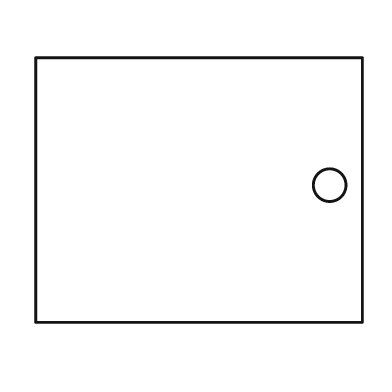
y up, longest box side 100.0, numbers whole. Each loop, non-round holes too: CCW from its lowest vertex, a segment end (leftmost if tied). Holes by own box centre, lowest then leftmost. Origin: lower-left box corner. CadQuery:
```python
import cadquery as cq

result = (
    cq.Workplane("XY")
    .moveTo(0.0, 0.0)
    .lineTo(100.0, 0.0)
    .lineTo(100.0, 81.0)
    .lineTo(0.0, 81.0)
    .close()
    .moveTo(90.0, 42.0)
    .circle(5.0)
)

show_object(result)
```